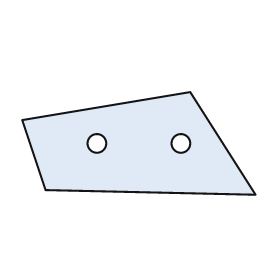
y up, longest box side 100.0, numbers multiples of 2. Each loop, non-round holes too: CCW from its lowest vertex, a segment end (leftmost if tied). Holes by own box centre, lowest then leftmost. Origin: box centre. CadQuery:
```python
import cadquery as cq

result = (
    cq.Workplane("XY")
    .moveTo(50.0, -22.0)
    .lineTo(22.0, 22.0)
    .lineTo(-50.0, 10.0)
    .lineTo(-40.0, -20.0)
    .close()
    .moveTo(-18.0, 0.0)
    .circle(4.0)
    .moveTo(18.0, 0.0)
    .circle(4.0)
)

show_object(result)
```